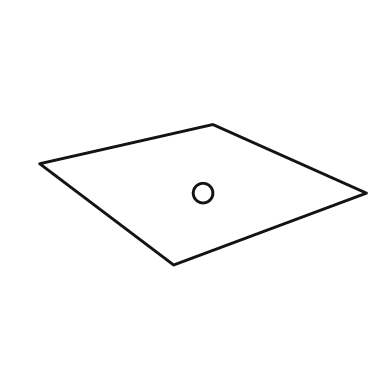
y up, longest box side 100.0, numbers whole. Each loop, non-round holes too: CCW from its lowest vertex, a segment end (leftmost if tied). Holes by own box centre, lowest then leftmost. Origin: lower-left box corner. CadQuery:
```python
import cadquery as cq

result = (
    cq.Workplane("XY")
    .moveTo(41.0, 0.0)
    .lineTo(100.0, 22.0)
    .lineTo(53.0, 43.0)
    .lineTo(0.0, 31.0)
    .close()
    .moveTo(50.0, 22.0)
    .circle(3.0)
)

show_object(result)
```